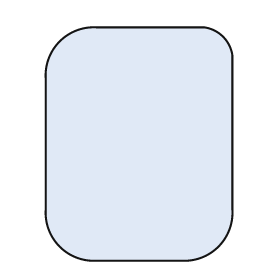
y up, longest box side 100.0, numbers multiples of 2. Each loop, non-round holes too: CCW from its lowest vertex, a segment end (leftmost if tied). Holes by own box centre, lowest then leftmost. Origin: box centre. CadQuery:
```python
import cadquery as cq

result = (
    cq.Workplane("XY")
    .moveTo(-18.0, -50.0)
    .lineTo(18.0, -50.0)
    .threePointArc((34.0, -44.0), (40.0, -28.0))
    .lineTo(40.0, 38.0)
    .threePointArc((36.0, 46.0), (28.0, 50.0))
    .lineTo(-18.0, 50.0)
    .threePointArc((-34.0, 44.0), (-40.0, 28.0))
    .lineTo(-40.0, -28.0)
    .threePointArc((-34.0, -44.0), (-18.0, -50.0))
    .close()
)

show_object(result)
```